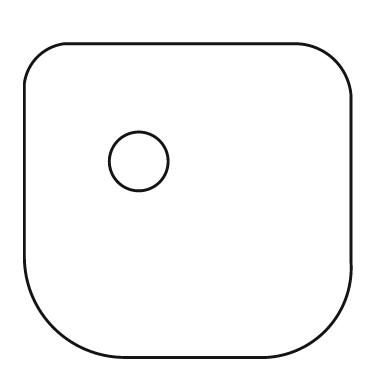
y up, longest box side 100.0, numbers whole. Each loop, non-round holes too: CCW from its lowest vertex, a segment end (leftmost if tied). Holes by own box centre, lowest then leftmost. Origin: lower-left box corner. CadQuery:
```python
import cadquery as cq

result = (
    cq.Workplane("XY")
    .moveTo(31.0, 0.0)
    .lineTo(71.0, 0.0)
    .threePointArc((92.0, 8.0), (100.0, 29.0))
    .lineTo(100.0, 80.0)
    .threePointArc((95.0, 91.0), (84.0, 96.0))
    .lineTo(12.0, 96.0)
    .threePointArc((4.0, 92.0), (0.0, 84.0))
    .lineTo(0.0, 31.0)
    .threePointArc((9.0, 9.0), (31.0, 0.0))
    .close()
    .moveTo(35.0, 60.0)
    .circle(9.0)
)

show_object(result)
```